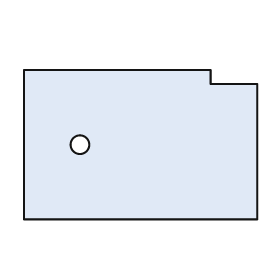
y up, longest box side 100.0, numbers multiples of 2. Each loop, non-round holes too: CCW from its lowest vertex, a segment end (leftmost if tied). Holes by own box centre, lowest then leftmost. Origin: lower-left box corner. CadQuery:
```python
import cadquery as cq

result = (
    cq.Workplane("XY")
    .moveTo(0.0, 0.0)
    .lineTo(100.0, 0.0)
    .lineTo(100.0, 58.0)
    .lineTo(80.0, 58.0)
    .lineTo(80.0, 64.0)
    .lineTo(0.0, 64.0)
    .close()
    .moveTo(24.0, 32.0)
    .circle(4.0)
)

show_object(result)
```